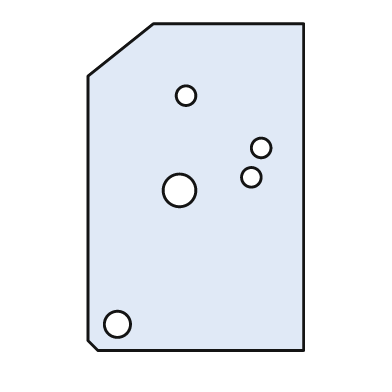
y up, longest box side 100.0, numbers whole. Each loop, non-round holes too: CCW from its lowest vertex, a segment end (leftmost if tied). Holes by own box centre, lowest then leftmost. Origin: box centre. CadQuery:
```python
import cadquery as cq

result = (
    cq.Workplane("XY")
    .moveTo(-30.0, -50.0)
    .lineTo(33.0, -50.0)
    .lineTo(33.0, 50.0)
    .lineTo(-13.0, 50.0)
    .lineTo(-33.0, 34.0)
    .lineTo(-33.0, -47.0)
    .close()
    .moveTo(-24.0, -42.0)
    .circle(4.0)
    .moveTo(-5.0, -1.0)
    .circle(5.0)
    .moveTo(17.0, 3.0)
    .circle(3.0)
    .moveTo(20.0, 12.0)
    .circle(3.0)
    .moveTo(-3.0, 28.0)
    .circle(3.0)
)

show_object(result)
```